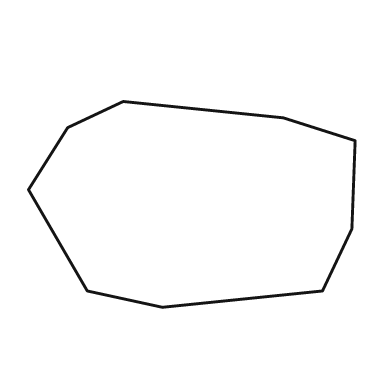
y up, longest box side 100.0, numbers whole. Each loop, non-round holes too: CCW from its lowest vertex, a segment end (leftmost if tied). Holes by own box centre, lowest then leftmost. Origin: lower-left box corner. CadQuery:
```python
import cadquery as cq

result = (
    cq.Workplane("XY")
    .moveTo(41.0, 0.0)
    .lineTo(90.0, 5.0)
    .lineTo(99.0, 24.0)
    .lineTo(100.0, 51.0)
    .lineTo(78.0, 58.0)
    .lineTo(29.0, 63.0)
    .lineTo(12.0, 55.0)
    .lineTo(0.0, 36.0)
    .lineTo(18.0, 5.0)
    .close()
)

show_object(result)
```